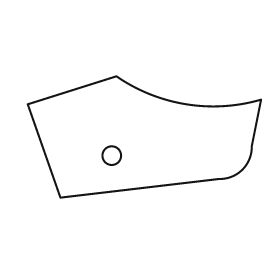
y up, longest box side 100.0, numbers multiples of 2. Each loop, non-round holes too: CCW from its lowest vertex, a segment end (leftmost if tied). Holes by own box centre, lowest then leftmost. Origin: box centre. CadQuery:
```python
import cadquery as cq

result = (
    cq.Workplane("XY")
    .moveTo(-36.0, -26.0)
    .lineTo(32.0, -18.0)
    .threePointArc((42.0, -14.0), (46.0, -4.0))
    .lineTo(50.0, 16.0)
    .threePointArc((18.0, 14.0), (-12.0, 26.0))
    .lineTo(-50.0, 14.0)
    .close()
    .moveTo(-14.0, -8.0)
    .circle(4.0)
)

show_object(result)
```